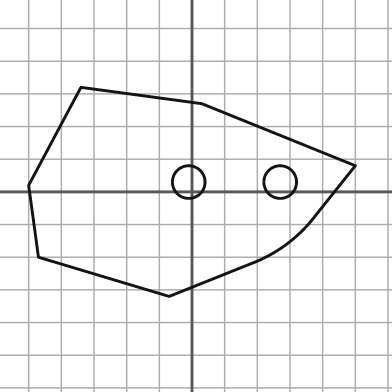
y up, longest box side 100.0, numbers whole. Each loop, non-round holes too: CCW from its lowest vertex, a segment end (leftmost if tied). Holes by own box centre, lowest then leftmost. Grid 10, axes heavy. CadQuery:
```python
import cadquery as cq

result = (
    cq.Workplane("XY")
    .moveTo(-7.0, -32.0)
    .lineTo(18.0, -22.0)
    .threePointArc((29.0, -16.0), (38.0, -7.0))
    .lineTo(50.0, 8.0)
    .lineTo(3.0, 27.0)
    .lineTo(-34.0, 32.0)
    .lineTo(-50.0, 2.0)
    .lineTo(-47.0, -20.0)
    .close()
    .moveTo(-1.0, 3.0)
    .circle(5.0)
    .moveTo(27.0, 3.0)
    .circle(5.0)
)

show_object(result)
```